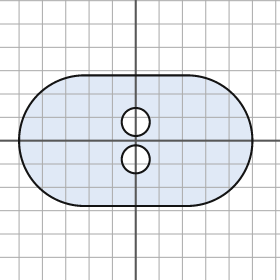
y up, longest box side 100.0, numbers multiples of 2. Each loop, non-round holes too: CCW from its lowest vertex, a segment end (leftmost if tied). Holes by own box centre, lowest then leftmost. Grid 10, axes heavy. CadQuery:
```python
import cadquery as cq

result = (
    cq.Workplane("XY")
    .moveTo(-22.0, -28.0)
    .lineTo(22.0, -28.0)
    .threePointArc((50.0, 0.0), (22.0, 28.0))
    .lineTo(-22.0, 28.0)
    .threePointArc((-50.0, 0.0), (-22.0, -28.0))
    .close()
    .moveTo(0.0, -8.0)
    .circle(6.0)
    .moveTo(0.0, 8.0)
    .circle(6.0)
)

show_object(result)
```